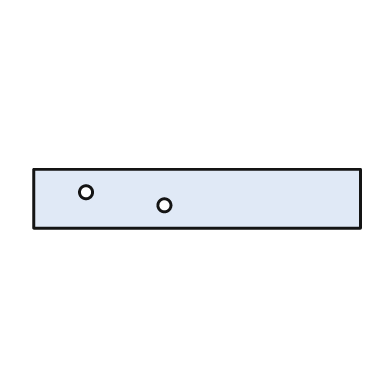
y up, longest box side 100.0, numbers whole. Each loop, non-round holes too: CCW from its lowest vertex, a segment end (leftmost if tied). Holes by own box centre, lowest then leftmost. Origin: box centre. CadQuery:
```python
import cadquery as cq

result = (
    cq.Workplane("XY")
    .moveTo(-50.0, -9.0)
    .lineTo(50.0, -9.0)
    .lineTo(50.0, 9.0)
    .lineTo(-50.0, 9.0)
    .close()
    .moveTo(-10.0, -2.0)
    .circle(2.0)
    .moveTo(-34.0, 2.0)
    .circle(2.0)
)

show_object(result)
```